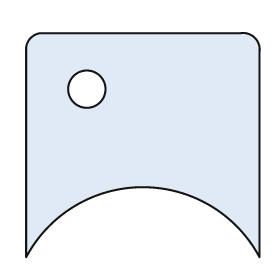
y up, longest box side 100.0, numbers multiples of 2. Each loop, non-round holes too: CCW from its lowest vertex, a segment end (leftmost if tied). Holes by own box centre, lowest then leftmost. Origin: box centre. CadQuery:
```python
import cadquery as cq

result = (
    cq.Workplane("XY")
    .moveTo(-50.0, -48.0)
    .threePointArc((0.0, -18.0), (50.0, -48.0))
    .lineTo(50.0, 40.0)
    .threePointArc((48.0, 46.0), (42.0, 48.0))
    .lineTo(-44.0, 48.0)
    .threePointArc((-48.0, 46.0), (-50.0, 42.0))
    .close()
    .moveTo(-24.0, 24.0)
    .circle(8.0)
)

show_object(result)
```